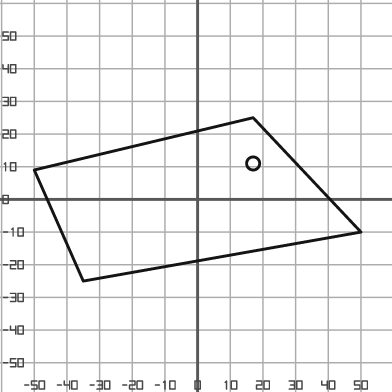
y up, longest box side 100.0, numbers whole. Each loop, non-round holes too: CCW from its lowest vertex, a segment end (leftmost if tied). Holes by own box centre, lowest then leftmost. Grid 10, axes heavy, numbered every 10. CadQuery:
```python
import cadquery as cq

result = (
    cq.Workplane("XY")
    .moveTo(-35.0, -25.0)
    .lineTo(50.0, -10.0)
    .lineTo(17.0, 25.0)
    .lineTo(-50.0, 9.0)
    .close()
    .moveTo(17.0, 11.0)
    .circle(2.0)
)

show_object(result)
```